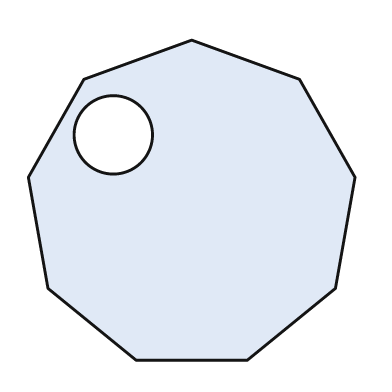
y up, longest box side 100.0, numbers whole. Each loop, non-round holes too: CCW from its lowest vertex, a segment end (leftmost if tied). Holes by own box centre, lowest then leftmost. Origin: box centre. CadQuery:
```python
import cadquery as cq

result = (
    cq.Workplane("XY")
    .moveTo(-17.0, -49.0)
    .lineTo(17.0, -49.0)
    .lineTo(44.0, -27.0)
    .lineTo(50.0, 7.0)
    .lineTo(33.0, 37.0)
    .lineTo(0.0, 49.0)
    .lineTo(-33.0, 37.0)
    .lineTo(-50.0, 7.0)
    .lineTo(-44.0, -27.0)
    .close()
    .moveTo(-24.0, 20.0)
    .circle(12.0)
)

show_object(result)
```